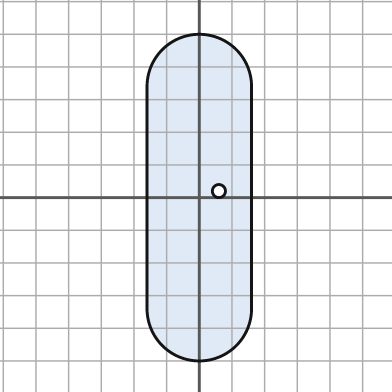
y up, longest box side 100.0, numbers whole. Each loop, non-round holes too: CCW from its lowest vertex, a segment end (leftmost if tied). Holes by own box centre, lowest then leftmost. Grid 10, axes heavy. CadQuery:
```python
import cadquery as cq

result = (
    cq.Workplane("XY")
    .moveTo(-16.0, -34.0)
    .threePointArc((0.0, -50.0), (16.0, -34.0))
    .lineTo(16.0, 34.0)
    .threePointArc((0.0, 50.0), (-16.0, 34.0))
    .close()
    .moveTo(6.0, 2.0)
    .circle(2.0)
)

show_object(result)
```